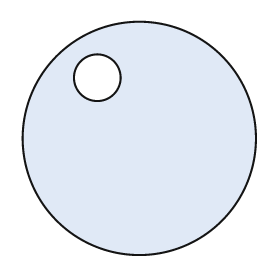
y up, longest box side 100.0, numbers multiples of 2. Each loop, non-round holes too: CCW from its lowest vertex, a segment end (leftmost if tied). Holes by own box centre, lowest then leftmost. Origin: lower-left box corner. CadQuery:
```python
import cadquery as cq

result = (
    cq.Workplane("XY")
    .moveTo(50.0, 50.0)
    .circle(50.0)
    .moveTo(32.0, 76.0)
    .circle(10.0)
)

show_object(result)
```